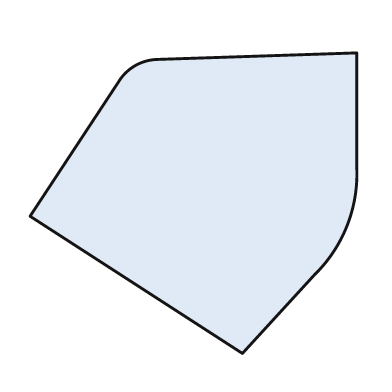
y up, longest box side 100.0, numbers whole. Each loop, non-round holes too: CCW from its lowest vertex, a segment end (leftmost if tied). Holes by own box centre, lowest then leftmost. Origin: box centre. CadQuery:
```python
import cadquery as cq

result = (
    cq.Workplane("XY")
    .moveTo(15.0, -46.0)
    .lineTo(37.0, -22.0)
    .threePointArc((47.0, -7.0), (50.0, 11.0))
    .lineTo(50.0, 46.0)
    .lineTo(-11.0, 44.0)
    .threePointArc((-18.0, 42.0), (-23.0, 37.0))
    .lineTo(-50.0, -4.0)
    .close()
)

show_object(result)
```